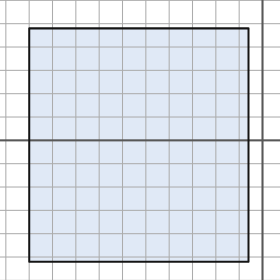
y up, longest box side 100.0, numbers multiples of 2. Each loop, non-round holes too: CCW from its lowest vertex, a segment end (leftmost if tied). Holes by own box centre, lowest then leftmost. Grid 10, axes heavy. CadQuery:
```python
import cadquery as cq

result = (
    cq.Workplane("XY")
    .moveTo(-100.0, -52.0)
    .lineTo(-6.0, -52.0)
    .lineTo(-6.0, 48.0)
    .lineTo(-100.0, 48.0)
    .close()
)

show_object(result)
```